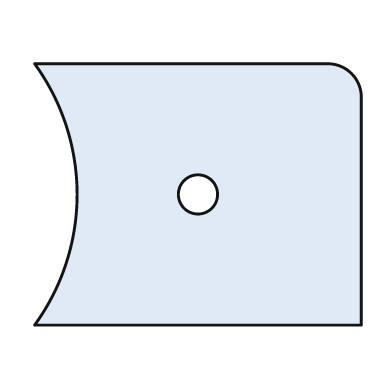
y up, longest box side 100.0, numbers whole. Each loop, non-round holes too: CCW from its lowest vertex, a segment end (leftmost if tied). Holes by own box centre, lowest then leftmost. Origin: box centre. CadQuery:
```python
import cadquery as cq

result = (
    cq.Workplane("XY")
    .moveTo(-50.0, -40.0)
    .lineTo(50.0, -40.0)
    .lineTo(50.0, 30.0)
    .threePointArc((47.0, 37.0), (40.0, 40.0))
    .lineTo(-50.0, 40.0)
    .threePointArc((-37.0, 0.0), (-50.0, -40.0))
    .close()
    .moveTo(0.0, 0.0)
    .circle(6.0)
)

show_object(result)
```